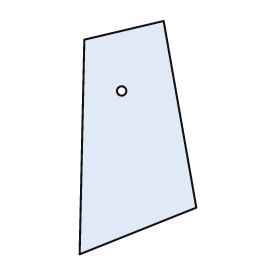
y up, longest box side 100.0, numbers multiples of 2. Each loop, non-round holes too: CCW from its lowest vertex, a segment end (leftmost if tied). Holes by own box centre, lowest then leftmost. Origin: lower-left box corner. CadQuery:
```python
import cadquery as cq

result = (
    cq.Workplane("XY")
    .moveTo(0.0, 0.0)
    .lineTo(50.0, 20.0)
    .lineTo(36.0, 100.0)
    .lineTo(2.0, 92.0)
    .close()
    .moveTo(18.0, 70.0)
    .circle(2.0)
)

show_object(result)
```